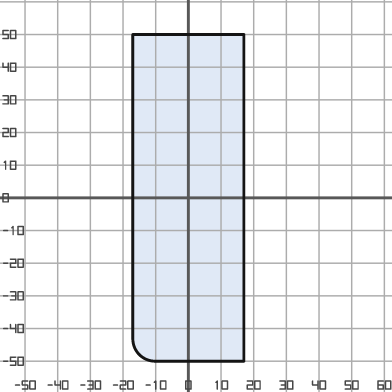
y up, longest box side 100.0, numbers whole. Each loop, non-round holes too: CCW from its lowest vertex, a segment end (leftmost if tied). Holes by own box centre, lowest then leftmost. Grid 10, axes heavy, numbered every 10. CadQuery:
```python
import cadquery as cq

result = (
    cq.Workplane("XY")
    .moveTo(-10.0, -50.0)
    .lineTo(17.0, -50.0)
    .lineTo(17.0, 50.0)
    .lineTo(-17.0, 50.0)
    .lineTo(-17.0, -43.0)
    .threePointArc((-15.0, -48.0), (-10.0, -50.0))
    .close()
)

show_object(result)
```